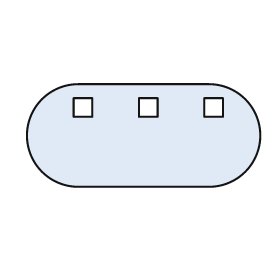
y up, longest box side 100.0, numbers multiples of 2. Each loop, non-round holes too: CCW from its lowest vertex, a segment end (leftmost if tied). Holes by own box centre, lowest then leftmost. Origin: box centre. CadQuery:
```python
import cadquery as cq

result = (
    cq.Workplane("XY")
    .moveTo(-28.0, -22.0)
    .lineTo(28.0, -22.0)
    .threePointArc((50.0, 0.0), (28.0, 22.0))
    .lineTo(-28.0, 22.0)
    .threePointArc((-50.0, 0.0), (-28.0, -22.0))
    .close()
    .moveTo(-30.0, 8.0)
    .lineTo(-22.0, 8.0)
    .lineTo(-22.0, 16.0)
    .lineTo(-30.0, 16.0)
    .close()
    .moveTo(-2.0, 8.0)
    .lineTo(6.0, 8.0)
    .lineTo(6.0, 16.0)
    .lineTo(-2.0, 16.0)
    .close()
    .moveTo(26.0, 8.0)
    .lineTo(34.0, 8.0)
    .lineTo(34.0, 16.0)
    .lineTo(26.0, 16.0)
    .close()
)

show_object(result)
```